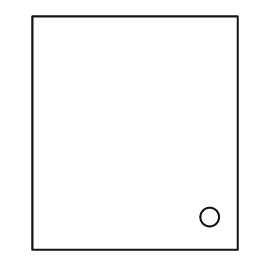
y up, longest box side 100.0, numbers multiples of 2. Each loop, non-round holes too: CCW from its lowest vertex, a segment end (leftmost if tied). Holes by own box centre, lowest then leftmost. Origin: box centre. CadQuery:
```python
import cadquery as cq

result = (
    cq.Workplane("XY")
    .moveTo(-44.0, -50.0)
    .lineTo(44.0, -50.0)
    .lineTo(44.0, 50.0)
    .lineTo(-44.0, 50.0)
    .close()
    .moveTo(32.0, -36.0)
    .circle(4.0)
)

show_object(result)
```